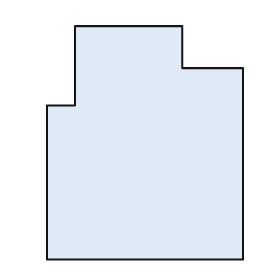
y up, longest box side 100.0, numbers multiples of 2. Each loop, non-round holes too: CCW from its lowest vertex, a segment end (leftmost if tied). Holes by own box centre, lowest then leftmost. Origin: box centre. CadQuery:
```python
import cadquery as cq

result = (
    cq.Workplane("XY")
    .moveTo(-42.0, -50.0)
    .lineTo(42.0, -50.0)
    .lineTo(42.0, 32.0)
    .lineTo(16.0, 32.0)
    .lineTo(16.0, 50.0)
    .lineTo(-30.0, 50.0)
    .lineTo(-30.0, 16.0)
    .lineTo(-42.0, 16.0)
    .close()
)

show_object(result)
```